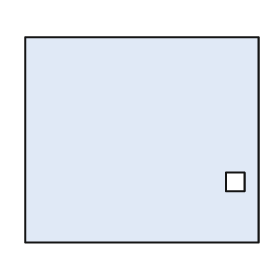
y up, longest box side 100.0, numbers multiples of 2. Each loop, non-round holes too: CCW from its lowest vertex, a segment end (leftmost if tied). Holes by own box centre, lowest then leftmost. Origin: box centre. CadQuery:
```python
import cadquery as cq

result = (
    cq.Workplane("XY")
    .moveTo(-50.0, -44.0)
    .lineTo(50.0, -44.0)
    .lineTo(50.0, 44.0)
    .lineTo(-50.0, 44.0)
    .close()
    .moveTo(36.0, -22.0)
    .lineTo(44.0, -22.0)
    .lineTo(44.0, -14.0)
    .lineTo(36.0, -14.0)
    .close()
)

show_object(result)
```